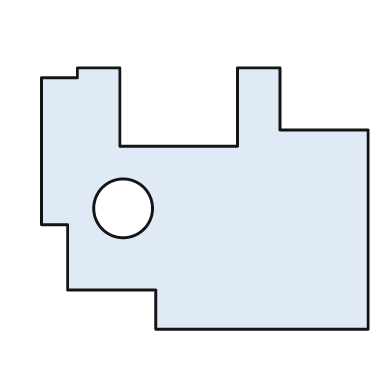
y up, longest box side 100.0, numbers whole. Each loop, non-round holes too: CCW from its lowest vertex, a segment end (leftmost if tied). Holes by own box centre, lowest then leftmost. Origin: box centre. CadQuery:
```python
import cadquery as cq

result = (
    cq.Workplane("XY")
    .moveTo(-15.0, -40.0)
    .lineTo(50.0, -40.0)
    .lineTo(50.0, 21.0)
    .lineTo(23.0, 21.0)
    .lineTo(23.0, 40.0)
    .lineTo(10.0, 40.0)
    .lineTo(10.0, 16.0)
    .lineTo(-26.0, 16.0)
    .lineTo(-26.0, 40.0)
    .lineTo(-39.0, 40.0)
    .lineTo(-39.0, 37.0)
    .lineTo(-50.0, 37.0)
    .lineTo(-50.0, -8.0)
    .lineTo(-42.0, -8.0)
    .lineTo(-42.0, -28.0)
    .lineTo(-15.0, -28.0)
    .close()
    .moveTo(-25.0, -3.0)
    .circle(9.0)
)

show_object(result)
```